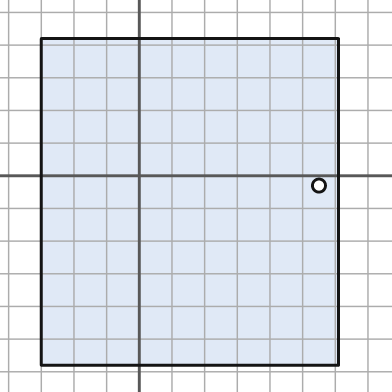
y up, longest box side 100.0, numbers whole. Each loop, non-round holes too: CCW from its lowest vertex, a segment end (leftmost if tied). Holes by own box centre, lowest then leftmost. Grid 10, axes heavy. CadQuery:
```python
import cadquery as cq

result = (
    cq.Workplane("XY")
    .moveTo(-30.0, -58.0)
    .lineTo(61.0, -58.0)
    .lineTo(61.0, 42.0)
    .lineTo(-30.0, 42.0)
    .close()
    .moveTo(55.0, -3.0)
    .circle(2.0)
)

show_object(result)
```